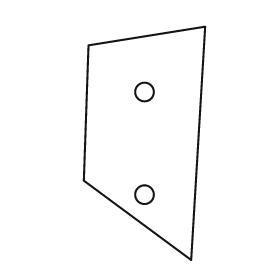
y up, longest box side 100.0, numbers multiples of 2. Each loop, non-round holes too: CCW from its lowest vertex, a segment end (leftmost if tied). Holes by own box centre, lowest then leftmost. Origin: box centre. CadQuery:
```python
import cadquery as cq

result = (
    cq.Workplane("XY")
    .moveTo(20.0, -50.0)
    .lineTo(26.0, 50.0)
    .lineTo(-24.0, 42.0)
    .lineTo(-26.0, -16.0)
    .close()
    .moveTo(0.0, -22.0)
    .circle(4.0)
    .moveTo(0.0, 22.0)
    .circle(4.0)
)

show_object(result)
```